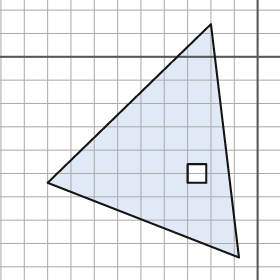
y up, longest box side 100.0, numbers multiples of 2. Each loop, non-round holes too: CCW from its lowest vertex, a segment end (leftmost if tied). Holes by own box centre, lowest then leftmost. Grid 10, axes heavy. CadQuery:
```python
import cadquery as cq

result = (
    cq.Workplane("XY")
    .moveTo(-8.0, -86.0)
    .lineTo(-20.0, 14.0)
    .lineTo(-90.0, -54.0)
    .close()
    .moveTo(-30.0, -54.0)
    .lineTo(-22.0, -54.0)
    .lineTo(-22.0, -46.0)
    .lineTo(-30.0, -46.0)
    .close()
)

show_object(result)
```